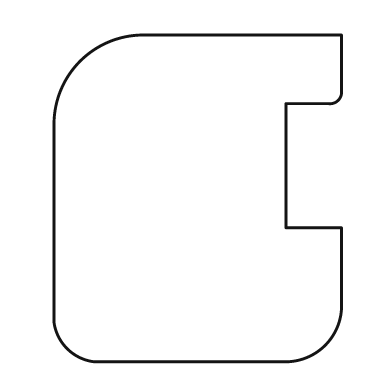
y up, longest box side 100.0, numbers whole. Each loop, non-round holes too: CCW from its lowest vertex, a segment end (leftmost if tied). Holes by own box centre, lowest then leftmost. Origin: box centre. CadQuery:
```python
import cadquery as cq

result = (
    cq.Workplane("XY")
    .moveTo(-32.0, -50.0)
    .lineTo(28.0, -50.0)
    .threePointArc((39.0, -45.0), (44.0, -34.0))
    .lineTo(44.0, -9.0)
    .lineTo(27.0, -9.0)
    .lineTo(27.0, 29.0)
    .lineTo(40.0, 29.0)
    .threePointArc((43.0, 30.0), (44.0, 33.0))
    .lineTo(44.0, 50.0)
    .lineTo(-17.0, 50.0)
    .threePointArc((-36.0, 42.0), (-44.0, 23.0))
    .lineTo(-44.0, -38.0)
    .threePointArc((-40.0, -46.0), (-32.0, -50.0))
    .close()
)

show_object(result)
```